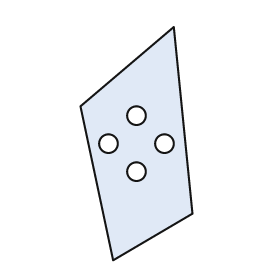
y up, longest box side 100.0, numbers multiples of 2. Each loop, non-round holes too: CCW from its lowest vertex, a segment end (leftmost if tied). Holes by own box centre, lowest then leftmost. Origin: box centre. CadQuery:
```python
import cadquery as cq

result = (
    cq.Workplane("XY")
    .moveTo(-10.0, -50.0)
    .lineTo(24.0, -30.0)
    .lineTo(16.0, 50.0)
    .lineTo(-24.0, 16.0)
    .close()
    .moveTo(0.0, -12.0)
    .circle(4.0)
    .moveTo(-12.0, 0.0)
    .circle(4.0)
    .moveTo(12.0, 0.0)
    .circle(4.0)
    .moveTo(0.0, 12.0)
    .circle(4.0)
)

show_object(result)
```